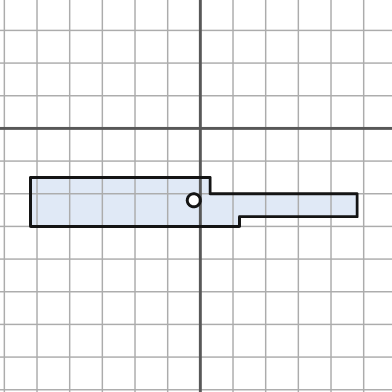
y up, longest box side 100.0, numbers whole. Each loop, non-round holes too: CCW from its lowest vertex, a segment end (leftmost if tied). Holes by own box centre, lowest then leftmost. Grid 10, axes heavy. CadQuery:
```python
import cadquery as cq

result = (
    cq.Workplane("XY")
    .moveTo(-52.0, -30.0)
    .lineTo(12.0, -30.0)
    .lineTo(12.0, -27.0)
    .lineTo(48.0, -27.0)
    .lineTo(48.0, -20.0)
    .lineTo(3.0, -20.0)
    .lineTo(3.0, -15.0)
    .lineTo(-52.0, -15.0)
    .close()
    .moveTo(-2.0, -22.0)
    .circle(2.0)
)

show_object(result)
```